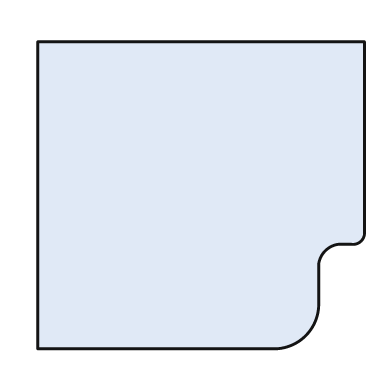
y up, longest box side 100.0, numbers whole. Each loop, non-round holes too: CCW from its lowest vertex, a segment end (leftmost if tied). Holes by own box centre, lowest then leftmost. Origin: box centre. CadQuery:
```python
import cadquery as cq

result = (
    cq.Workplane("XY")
    .moveTo(-50.0, -47.0)
    .lineTo(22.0, -47.0)
    .threePointArc((32.0, -43.0), (36.0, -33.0))
    .lineTo(36.0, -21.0)
    .threePointArc((38.0, -17.0), (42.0, -15.0))
    .lineTo(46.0, -15.0)
    .threePointArc((49.0, -14.0), (50.0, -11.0))
    .lineTo(50.0, 47.0)
    .lineTo(-50.0, 47.0)
    .close()
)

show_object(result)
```